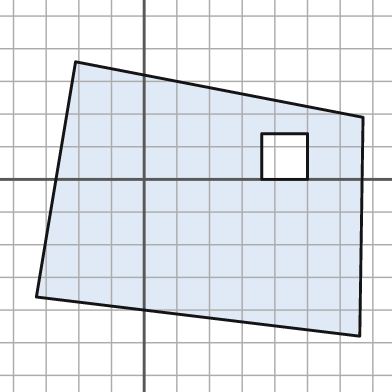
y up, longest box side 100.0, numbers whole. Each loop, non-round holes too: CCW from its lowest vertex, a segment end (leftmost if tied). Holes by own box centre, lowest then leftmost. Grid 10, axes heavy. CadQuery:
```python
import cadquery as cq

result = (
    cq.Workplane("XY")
    .moveTo(66.0, -48.0)
    .lineTo(67.0, 19.0)
    .lineTo(-21.0, 36.0)
    .lineTo(-33.0, -36.0)
    .close()
    .moveTo(36.0, 0.0)
    .lineTo(50.0, 0.0)
    .lineTo(50.0, 14.0)
    .lineTo(36.0, 14.0)
    .close()
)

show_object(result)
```